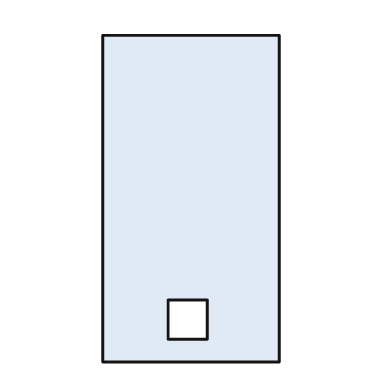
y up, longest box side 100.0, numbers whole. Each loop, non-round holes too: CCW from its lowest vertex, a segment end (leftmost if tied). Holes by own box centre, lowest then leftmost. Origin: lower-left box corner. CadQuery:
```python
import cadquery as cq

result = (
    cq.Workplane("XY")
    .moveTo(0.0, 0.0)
    .lineTo(54.0, 0.0)
    .lineTo(54.0, 100.0)
    .lineTo(0.0, 100.0)
    .close()
    .moveTo(20.0, 7.0)
    .lineTo(32.0, 7.0)
    .lineTo(32.0, 19.0)
    .lineTo(20.0, 19.0)
    .close()
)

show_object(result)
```